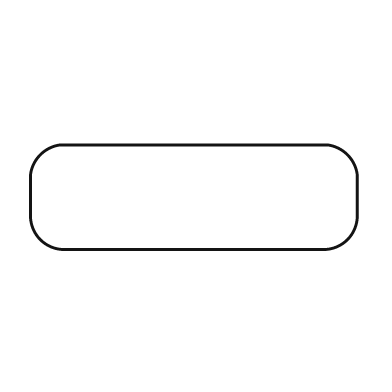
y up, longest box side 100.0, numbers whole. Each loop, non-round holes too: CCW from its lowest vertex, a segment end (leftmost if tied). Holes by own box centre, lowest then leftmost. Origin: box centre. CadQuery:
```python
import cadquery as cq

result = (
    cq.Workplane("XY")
    .moveTo(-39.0, -16.0)
    .lineTo(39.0, -16.0)
    .threePointArc((47.0, -13.0), (50.0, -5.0))
    .lineTo(50.0, 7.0)
    .threePointArc((47.0, 13.0), (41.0, 16.0))
    .lineTo(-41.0, 16.0)
    .threePointArc((-47.0, 13.0), (-50.0, 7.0))
    .lineTo(-50.0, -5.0)
    .threePointArc((-47.0, -13.0), (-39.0, -16.0))
    .close()
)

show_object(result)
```